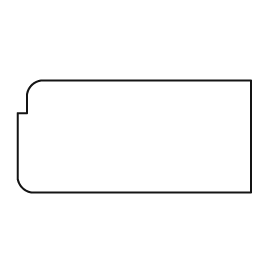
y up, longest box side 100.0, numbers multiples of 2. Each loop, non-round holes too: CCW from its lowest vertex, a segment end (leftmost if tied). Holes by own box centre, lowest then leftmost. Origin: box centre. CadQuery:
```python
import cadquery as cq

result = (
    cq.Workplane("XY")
    .moveTo(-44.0, -24.0)
    .lineTo(50.0, -24.0)
    .lineTo(50.0, 24.0)
    .lineTo(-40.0, 24.0)
    .threePointArc((-44.0, 22.0), (-46.0, 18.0))
    .lineTo(-46.0, 10.0)
    .lineTo(-50.0, 10.0)
    .lineTo(-50.0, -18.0)
    .threePointArc((-48.0, -22.0), (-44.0, -24.0))
    .close()
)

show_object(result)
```